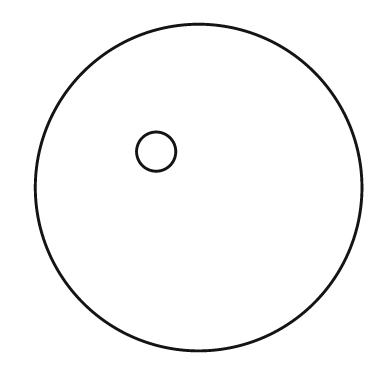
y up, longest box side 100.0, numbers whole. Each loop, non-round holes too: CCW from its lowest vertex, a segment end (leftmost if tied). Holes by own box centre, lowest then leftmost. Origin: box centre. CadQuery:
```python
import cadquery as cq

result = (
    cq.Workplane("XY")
    .moveTo(0.0, 0.0)
    .circle(50.0)
    .moveTo(-13.0, 11.0)
    .circle(6.0)
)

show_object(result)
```